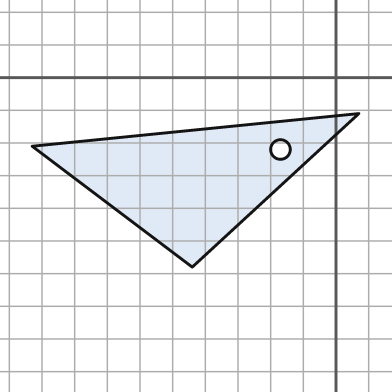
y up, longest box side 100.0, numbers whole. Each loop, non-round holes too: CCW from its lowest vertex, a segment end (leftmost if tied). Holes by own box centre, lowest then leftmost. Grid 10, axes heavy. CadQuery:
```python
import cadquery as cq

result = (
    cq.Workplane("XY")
    .moveTo(-44.0, -58.0)
    .lineTo(7.0, -11.0)
    .lineTo(-93.0, -21.0)
    .close()
    .moveTo(-17.0, -22.0)
    .circle(3.0)
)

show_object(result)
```